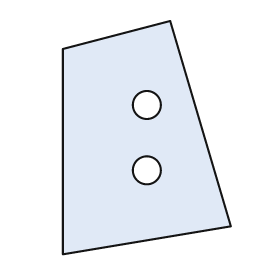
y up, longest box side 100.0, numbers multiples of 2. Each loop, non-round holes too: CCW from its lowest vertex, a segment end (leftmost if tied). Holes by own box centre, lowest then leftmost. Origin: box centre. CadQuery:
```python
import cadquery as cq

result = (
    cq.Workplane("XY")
    .moveTo(-36.0, -50.0)
    .lineTo(36.0, -38.0)
    .lineTo(10.0, 50.0)
    .lineTo(-36.0, 38.0)
    .close()
    .moveTo(0.0, -14.0)
    .circle(6.0)
    .moveTo(0.0, 14.0)
    .circle(6.0)
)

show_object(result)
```